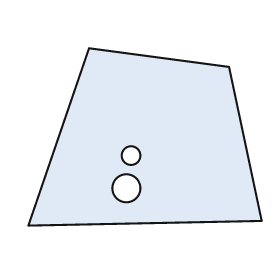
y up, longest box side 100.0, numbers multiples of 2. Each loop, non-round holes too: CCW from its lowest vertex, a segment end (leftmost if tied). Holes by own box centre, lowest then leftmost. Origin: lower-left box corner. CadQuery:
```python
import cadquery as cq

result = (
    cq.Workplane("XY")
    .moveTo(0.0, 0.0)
    .lineTo(100.0, 2.0)
    .lineTo(86.0, 68.0)
    .lineTo(26.0, 76.0)
    .close()
    .moveTo(42.0, 16.0)
    .circle(6.0)
    .moveTo(44.0, 30.0)
    .circle(4.0)
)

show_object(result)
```